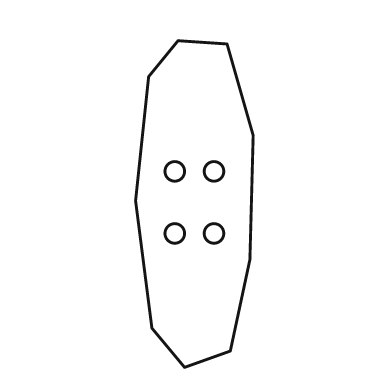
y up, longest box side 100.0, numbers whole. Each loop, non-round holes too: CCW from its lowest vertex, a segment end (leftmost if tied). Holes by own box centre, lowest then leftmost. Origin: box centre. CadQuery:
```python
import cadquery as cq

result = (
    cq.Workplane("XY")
    .moveTo(-3.0, -50.0)
    .lineTo(11.0, -45.0)
    .lineTo(17.0, -17.0)
    .lineTo(18.0, 21.0)
    .lineTo(10.0, 49.0)
    .lineTo(-5.0, 50.0)
    .lineTo(-14.0, 39.0)
    .lineTo(-18.0, 1.0)
    .lineTo(-13.0, -38.0)
    .close()
    .moveTo(-6.0, -9.0)
    .circle(3.0)
    .moveTo(6.0, -9.0)
    .circle(3.0)
    .moveTo(-6.0, 10.0)
    .circle(3.0)
    .moveTo(6.0, 10.0)
    .circle(3.0)
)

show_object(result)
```